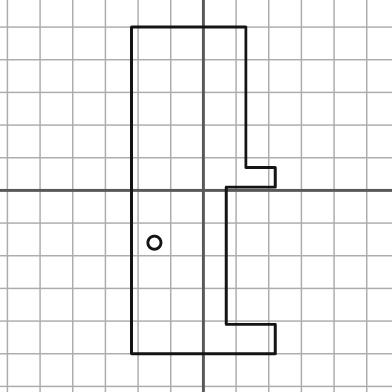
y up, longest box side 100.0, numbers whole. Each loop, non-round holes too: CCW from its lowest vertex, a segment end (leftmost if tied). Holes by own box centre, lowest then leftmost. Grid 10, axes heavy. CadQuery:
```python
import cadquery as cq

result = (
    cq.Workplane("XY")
    .moveTo(-22.0, -50.0)
    .lineTo(22.0, -50.0)
    .lineTo(22.0, -41.0)
    .lineTo(7.0, -41.0)
    .lineTo(7.0, 1.0)
    .lineTo(22.0, 1.0)
    .lineTo(22.0, 7.0)
    .lineTo(13.0, 7.0)
    .lineTo(13.0, 50.0)
    .lineTo(-22.0, 50.0)
    .close()
    .moveTo(-15.0, -16.0)
    .circle(2.0)
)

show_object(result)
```